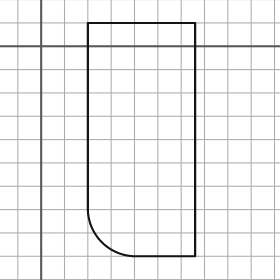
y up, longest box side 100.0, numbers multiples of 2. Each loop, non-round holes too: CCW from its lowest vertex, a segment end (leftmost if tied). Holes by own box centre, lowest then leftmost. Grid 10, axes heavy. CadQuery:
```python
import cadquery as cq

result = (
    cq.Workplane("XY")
    .moveTo(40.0, -90.0)
    .lineTo(66.0, -90.0)
    .lineTo(66.0, 10.0)
    .lineTo(20.0, 10.0)
    .lineTo(20.0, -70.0)
    .threePointArc((26.0, -84.0), (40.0, -90.0))
    .close()
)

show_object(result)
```